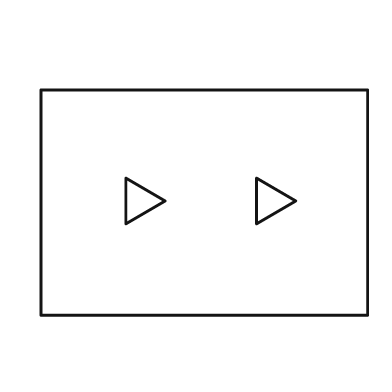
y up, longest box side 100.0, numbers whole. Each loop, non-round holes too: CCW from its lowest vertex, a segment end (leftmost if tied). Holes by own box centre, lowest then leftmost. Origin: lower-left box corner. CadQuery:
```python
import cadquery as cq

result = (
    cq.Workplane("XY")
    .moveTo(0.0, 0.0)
    .lineTo(100.0, 0.0)
    .lineTo(100.0, 69.0)
    .lineTo(0.0, 69.0)
    .close()
    .moveTo(26.0, 28.0)
    .lineTo(38.0, 35.0)
    .lineTo(26.0, 42.0)
    .close()
    .moveTo(66.0, 28.0)
    .lineTo(78.0, 35.0)
    .lineTo(66.0, 42.0)
    .close()
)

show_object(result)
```